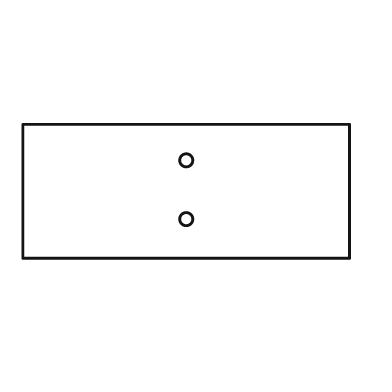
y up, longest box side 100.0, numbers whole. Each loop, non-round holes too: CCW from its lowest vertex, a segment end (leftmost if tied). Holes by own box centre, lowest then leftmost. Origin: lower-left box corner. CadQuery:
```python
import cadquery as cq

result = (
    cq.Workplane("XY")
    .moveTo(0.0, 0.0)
    .lineTo(100.0, 0.0)
    .lineTo(100.0, 41.0)
    .lineTo(0.0, 41.0)
    .close()
    .moveTo(50.0, 12.0)
    .circle(2.0)
    .moveTo(50.0, 30.0)
    .circle(2.0)
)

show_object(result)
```